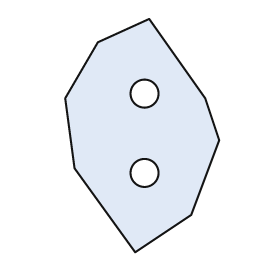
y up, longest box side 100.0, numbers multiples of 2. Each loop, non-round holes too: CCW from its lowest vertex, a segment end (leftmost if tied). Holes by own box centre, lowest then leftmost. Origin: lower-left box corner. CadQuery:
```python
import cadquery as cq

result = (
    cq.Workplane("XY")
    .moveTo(30.0, 0.0)
    .lineTo(54.0, 16.0)
    .lineTo(66.0, 48.0)
    .lineTo(60.0, 66.0)
    .lineTo(36.0, 100.0)
    .lineTo(14.0, 90.0)
    .lineTo(0.0, 66.0)
    .lineTo(4.0, 36.0)
    .close()
    .moveTo(34.0, 34.0)
    .circle(6.0)
    .moveTo(34.0, 68.0)
    .circle(6.0)
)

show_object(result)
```